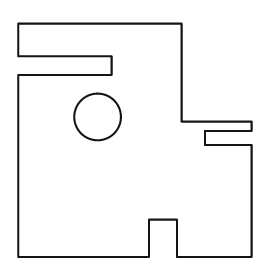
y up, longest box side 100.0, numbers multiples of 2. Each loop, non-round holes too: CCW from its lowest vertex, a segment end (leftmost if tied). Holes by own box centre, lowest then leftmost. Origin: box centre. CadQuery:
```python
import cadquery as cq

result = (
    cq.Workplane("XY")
    .moveTo(-50.0, -50.0)
    .lineTo(6.0, -50.0)
    .lineTo(6.0, -34.0)
    .lineTo(18.0, -34.0)
    .lineTo(18.0, -50.0)
    .lineTo(50.0, -50.0)
    .lineTo(50.0, -2.0)
    .lineTo(30.0, -2.0)
    .lineTo(30.0, 4.0)
    .lineTo(50.0, 4.0)
    .lineTo(50.0, 8.0)
    .lineTo(20.0, 8.0)
    .lineTo(20.0, 50.0)
    .lineTo(-50.0, 50.0)
    .lineTo(-50.0, 36.0)
    .lineTo(-10.0, 36.0)
    .lineTo(-10.0, 28.0)
    .lineTo(-50.0, 28.0)
    .close()
    .moveTo(-16.0, 10.0)
    .circle(10.0)
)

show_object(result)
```